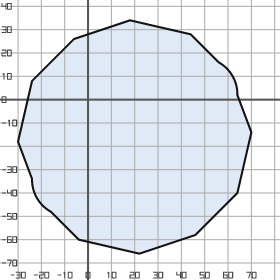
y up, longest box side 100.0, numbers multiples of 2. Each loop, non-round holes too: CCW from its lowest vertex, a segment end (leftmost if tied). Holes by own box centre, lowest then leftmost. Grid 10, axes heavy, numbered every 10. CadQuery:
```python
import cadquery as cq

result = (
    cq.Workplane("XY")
    .moveTo(22.0, -66.0)
    .lineTo(46.0, -58.0)
    .lineTo(64.0, -40.0)
    .lineTo(70.0, -14.0)
    .lineTo(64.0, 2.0)
    .threePointArc((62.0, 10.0), (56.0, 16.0))
    .lineTo(44.0, 28.0)
    .lineTo(18.0, 34.0)
    .lineTo(-6.0, 26.0)
    .lineTo(-24.0, 8.0)
    .lineTo(-30.0, -18.0)
    .lineTo(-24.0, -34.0)
    .threePointArc((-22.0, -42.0), (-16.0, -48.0))
    .lineTo(-4.0, -60.0)
    .close()
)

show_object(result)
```